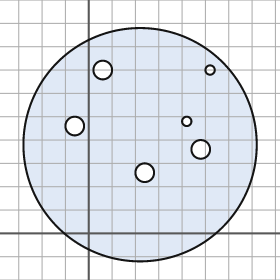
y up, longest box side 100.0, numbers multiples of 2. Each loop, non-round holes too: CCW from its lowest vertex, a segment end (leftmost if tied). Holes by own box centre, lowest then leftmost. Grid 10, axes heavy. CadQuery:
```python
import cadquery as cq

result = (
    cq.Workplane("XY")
    .moveTo(22.0, 38.0)
    .circle(50.0)
    .moveTo(24.0, 26.0)
    .circle(4.0)
    .moveTo(48.0, 36.0)
    .circle(4.0)
    .moveTo(-6.0, 46.0)
    .circle(4.0)
    .moveTo(42.0, 48.0)
    .circle(2.0)
    .moveTo(6.0, 70.0)
    .circle(4.0)
    .moveTo(52.0, 70.0)
    .circle(2.0)
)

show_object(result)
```